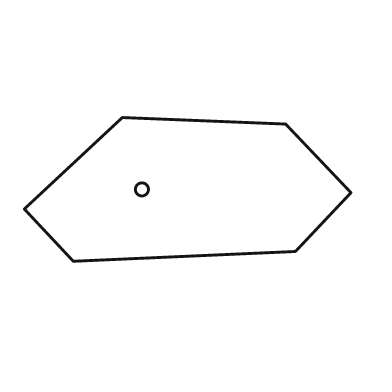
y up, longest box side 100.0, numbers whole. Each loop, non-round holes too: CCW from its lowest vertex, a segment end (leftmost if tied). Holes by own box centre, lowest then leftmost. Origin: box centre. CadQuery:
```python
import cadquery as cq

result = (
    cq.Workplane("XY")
    .moveTo(-35.0, -22.0)
    .lineTo(33.0, -19.0)
    .lineTo(50.0, -1.0)
    .lineTo(30.0, 20.0)
    .lineTo(-20.0, 22.0)
    .lineTo(-50.0, -6.0)
    .close()
    .moveTo(-14.0, 0.0)
    .circle(2.0)
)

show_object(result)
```